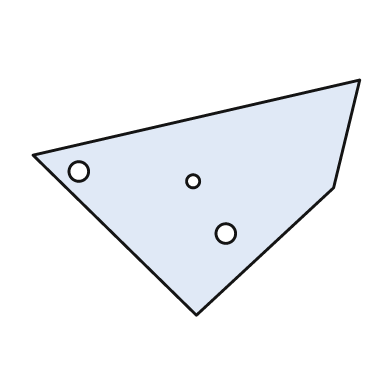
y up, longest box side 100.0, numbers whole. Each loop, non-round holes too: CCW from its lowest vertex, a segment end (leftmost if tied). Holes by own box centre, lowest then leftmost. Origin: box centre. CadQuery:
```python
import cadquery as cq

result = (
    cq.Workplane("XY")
    .moveTo(0.0, -36.0)
    .lineTo(42.0, 3.0)
    .lineTo(50.0, 36.0)
    .lineTo(-50.0, 13.0)
    .close()
    .moveTo(9.0, -11.0)
    .circle(3.0)
    .moveTo(-1.0, 5.0)
    .circle(2.0)
    .moveTo(-36.0, 8.0)
    .circle(3.0)
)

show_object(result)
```